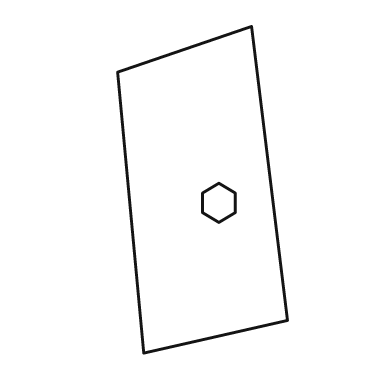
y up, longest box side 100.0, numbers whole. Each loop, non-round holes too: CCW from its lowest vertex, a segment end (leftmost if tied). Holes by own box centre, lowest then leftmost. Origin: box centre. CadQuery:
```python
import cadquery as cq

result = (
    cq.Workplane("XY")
    .moveTo(-18.0, -50.0)
    .lineTo(26.0, -40.0)
    .lineTo(15.0, 50.0)
    .lineTo(-26.0, 36.0)
    .close()
    .moveTo(5.0, -10.0)
    .lineTo(10.0, -7.0)
    .lineTo(10.0, -1.0)
    .lineTo(5.0, 2.0)
    .lineTo(0.0, -1.0)
    .lineTo(0.0, -7.0)
    .close()
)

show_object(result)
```